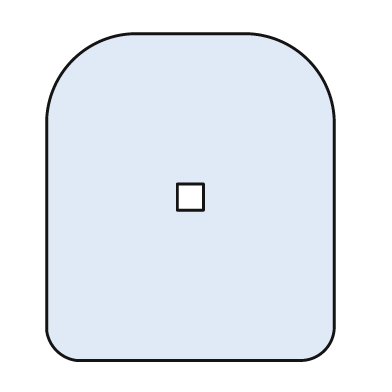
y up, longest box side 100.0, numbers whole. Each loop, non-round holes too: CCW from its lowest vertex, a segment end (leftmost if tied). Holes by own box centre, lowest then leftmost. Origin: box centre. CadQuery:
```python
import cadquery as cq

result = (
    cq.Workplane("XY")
    .moveTo(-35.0, -50.0)
    .lineTo(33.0, -50.0)
    .threePointArc((41.0, -47.0), (44.0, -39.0))
    .lineTo(44.0, 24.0)
    .threePointArc((36.0, 42.0), (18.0, 50.0))
    .lineTo(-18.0, 50.0)
    .threePointArc((-36.0, 42.0), (-44.0, 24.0))
    .lineTo(-44.0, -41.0)
    .threePointArc((-41.0, -47.0), (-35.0, -50.0))
    .close()
    .moveTo(-4.0, -4.0)
    .lineTo(4.0, -4.0)
    .lineTo(4.0, 4.0)
    .lineTo(-4.0, 4.0)
    .close()
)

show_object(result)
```